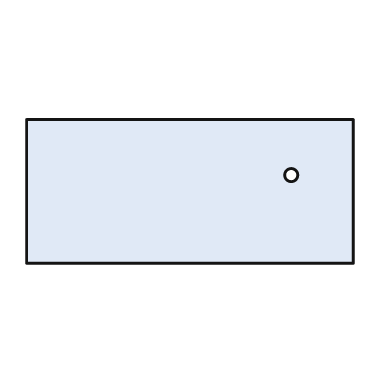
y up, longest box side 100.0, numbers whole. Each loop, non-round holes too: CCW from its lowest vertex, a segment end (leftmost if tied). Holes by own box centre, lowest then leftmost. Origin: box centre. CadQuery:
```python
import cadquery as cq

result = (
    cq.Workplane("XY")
    .moveTo(-50.0, -22.0)
    .lineTo(50.0, -22.0)
    .lineTo(50.0, 22.0)
    .lineTo(-50.0, 22.0)
    .close()
    .moveTo(31.0, 5.0)
    .circle(2.0)
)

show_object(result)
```